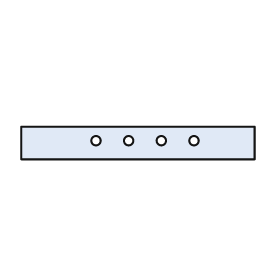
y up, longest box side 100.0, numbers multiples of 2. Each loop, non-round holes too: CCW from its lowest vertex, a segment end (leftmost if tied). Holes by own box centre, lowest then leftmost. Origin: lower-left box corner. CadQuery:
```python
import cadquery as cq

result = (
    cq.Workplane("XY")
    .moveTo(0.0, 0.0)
    .lineTo(100.0, 0.0)
    .lineTo(100.0, 14.0)
    .lineTo(0.0, 14.0)
    .close()
    .moveTo(32.0, 8.0)
    .circle(2.0)
    .moveTo(46.0, 8.0)
    .circle(2.0)
    .moveTo(60.0, 8.0)
    .circle(2.0)
    .moveTo(74.0, 8.0)
    .circle(2.0)
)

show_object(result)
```